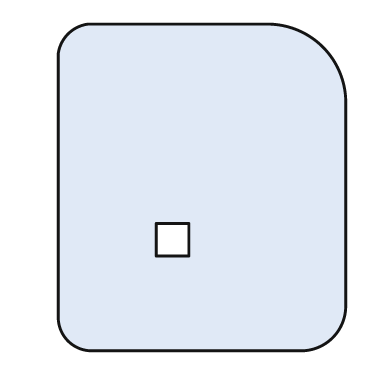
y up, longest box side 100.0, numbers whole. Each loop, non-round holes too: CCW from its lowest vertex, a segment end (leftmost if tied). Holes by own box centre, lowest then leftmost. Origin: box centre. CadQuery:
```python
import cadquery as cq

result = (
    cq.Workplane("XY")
    .moveTo(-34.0, -50.0)
    .lineTo(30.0, -50.0)
    .threePointArc((40.0, -46.0), (44.0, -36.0))
    .lineTo(44.0, 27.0)
    .threePointArc((37.0, 43.0), (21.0, 50.0))
    .lineTo(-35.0, 50.0)
    .threePointArc((-41.0, 47.0), (-44.0, 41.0))
    .lineTo(-44.0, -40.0)
    .threePointArc((-41.0, -47.0), (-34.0, -50.0))
    .close()
    .moveTo(-14.0, -21.0)
    .lineTo(-4.0, -21.0)
    .lineTo(-4.0, -11.0)
    .lineTo(-14.0, -11.0)
    .close()
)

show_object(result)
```